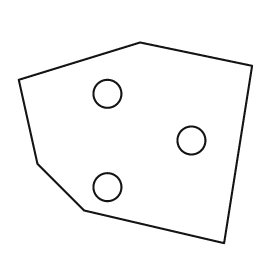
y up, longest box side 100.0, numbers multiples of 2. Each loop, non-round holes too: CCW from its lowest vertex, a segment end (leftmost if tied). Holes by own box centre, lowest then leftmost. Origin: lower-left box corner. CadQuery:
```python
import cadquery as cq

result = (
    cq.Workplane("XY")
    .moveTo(88.0, 0.0)
    .lineTo(100.0, 76.0)
    .lineTo(52.0, 86.0)
    .lineTo(0.0, 70.0)
    .lineTo(8.0, 34.0)
    .lineTo(28.0, 14.0)
    .close()
    .moveTo(38.0, 24.0)
    .circle(6.0)
    .moveTo(74.0, 44.0)
    .circle(6.0)
    .moveTo(38.0, 64.0)
    .circle(6.0)
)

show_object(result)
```